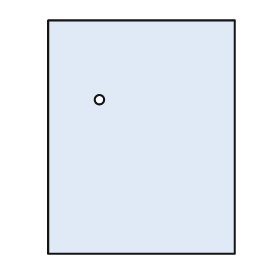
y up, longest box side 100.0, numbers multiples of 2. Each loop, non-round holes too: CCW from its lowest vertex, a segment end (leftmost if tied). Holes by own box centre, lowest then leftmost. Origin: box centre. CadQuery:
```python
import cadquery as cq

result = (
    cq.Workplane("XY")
    .moveTo(-40.0, -50.0)
    .lineTo(40.0, -50.0)
    .lineTo(40.0, 50.0)
    .lineTo(-40.0, 50.0)
    .close()
    .moveTo(-18.0, 16.0)
    .circle(2.0)
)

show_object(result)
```